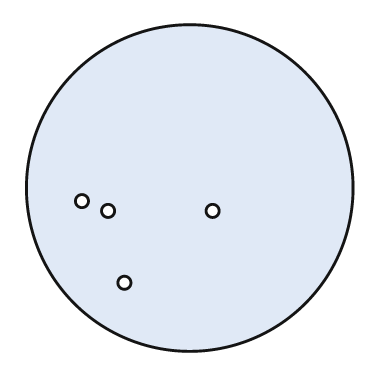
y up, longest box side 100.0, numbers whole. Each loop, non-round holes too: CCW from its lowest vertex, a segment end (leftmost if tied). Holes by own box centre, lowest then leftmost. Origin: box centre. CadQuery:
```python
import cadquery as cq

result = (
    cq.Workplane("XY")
    .moveTo(0.0, 0.0)
    .circle(50.0)
    .moveTo(-20.0, -29.0)
    .circle(2.0)
    .moveTo(-25.0, -7.0)
    .circle(2.0)
    .moveTo(7.0, -7.0)
    .circle(2.0)
    .moveTo(-33.0, -4.0)
    .circle(2.0)
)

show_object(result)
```